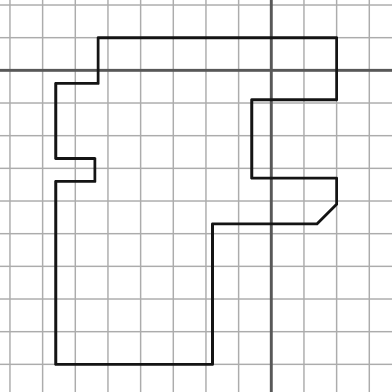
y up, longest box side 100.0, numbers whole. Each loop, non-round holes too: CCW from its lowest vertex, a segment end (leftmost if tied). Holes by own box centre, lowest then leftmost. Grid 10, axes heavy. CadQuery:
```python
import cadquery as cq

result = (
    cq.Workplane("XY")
    .moveTo(-66.0, -90.0)
    .lineTo(-18.0, -90.0)
    .lineTo(-18.0, -47.0)
    .lineTo(14.0, -47.0)
    .lineTo(20.0, -41.0)
    .lineTo(20.0, -33.0)
    .lineTo(-6.0, -33.0)
    .lineTo(-6.0, -9.0)
    .lineTo(20.0, -9.0)
    .lineTo(20.0, 10.0)
    .lineTo(-53.0, 10.0)
    .lineTo(-53.0, -4.0)
    .lineTo(-66.0, -4.0)
    .lineTo(-66.0, -27.0)
    .lineTo(-54.0, -27.0)
    .lineTo(-54.0, -34.0)
    .lineTo(-66.0, -34.0)
    .close()
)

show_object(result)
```